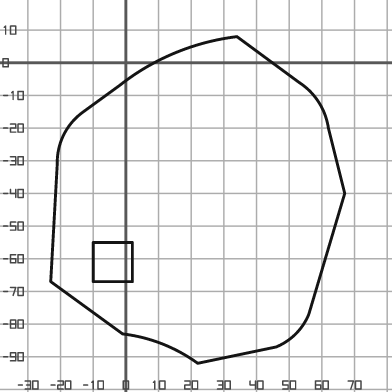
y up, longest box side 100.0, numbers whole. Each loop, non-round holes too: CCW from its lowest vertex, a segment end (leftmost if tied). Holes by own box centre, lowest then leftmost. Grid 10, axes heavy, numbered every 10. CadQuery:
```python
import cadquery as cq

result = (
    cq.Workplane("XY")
    .moveTo(22.0, -92.0)
    .lineTo(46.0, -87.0)
    .threePointArc((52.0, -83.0), (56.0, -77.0))
    .lineTo(67.0, -40.0)
    .lineTo(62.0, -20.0)
    .threePointArc((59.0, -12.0), (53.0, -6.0))
    .lineTo(34.0, 8.0)
    .threePointArc((15.0, 3.0), (-2.0, -7.0))
    .lineTo(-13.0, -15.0)
    .threePointArc((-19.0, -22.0), (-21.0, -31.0))
    .lineTo(-23.0, -67.0)
    .lineTo(-1.0, -83.0)
    .threePointArc((11.0, -86.0), (22.0, -92.0))
    .close()
    .moveTo(-10.0, -67.0)
    .lineTo(2.0, -67.0)
    .lineTo(2.0, -55.0)
    .lineTo(-10.0, -55.0)
    .close()
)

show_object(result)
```